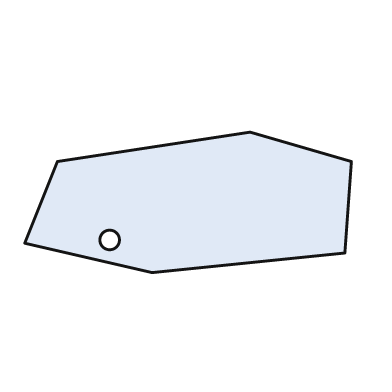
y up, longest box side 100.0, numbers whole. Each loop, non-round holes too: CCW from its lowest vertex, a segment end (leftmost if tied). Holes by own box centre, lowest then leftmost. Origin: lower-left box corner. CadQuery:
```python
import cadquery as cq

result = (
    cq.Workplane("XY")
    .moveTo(39.0, 0.0)
    .lineTo(98.0, 6.0)
    .lineTo(100.0, 34.0)
    .lineTo(69.0, 43.0)
    .lineTo(10.0, 34.0)
    .lineTo(0.0, 9.0)
    .close()
    .moveTo(26.0, 10.0)
    .circle(3.0)
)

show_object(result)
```